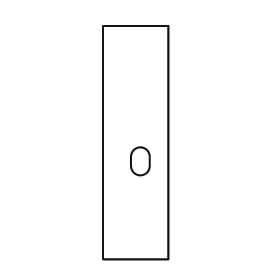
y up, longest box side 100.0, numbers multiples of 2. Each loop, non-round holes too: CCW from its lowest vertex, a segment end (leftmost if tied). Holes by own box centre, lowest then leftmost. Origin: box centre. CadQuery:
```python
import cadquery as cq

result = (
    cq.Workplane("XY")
    .moveTo(-14.0, -50.0)
    .lineTo(14.0, -50.0)
    .lineTo(14.0, 50.0)
    .lineTo(-14.0, 50.0)
    .close()
    .moveTo(-2.0, -10.0)
    .threePointArc((2.0, -14.0), (6.0, -10.0))
    .lineTo(6.0, -6.0)
    .threePointArc((2.0, -2.0), (-2.0, -6.0))
    .close()
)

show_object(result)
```